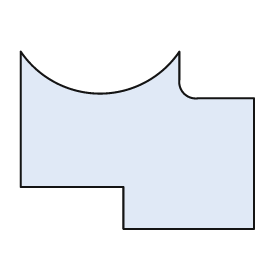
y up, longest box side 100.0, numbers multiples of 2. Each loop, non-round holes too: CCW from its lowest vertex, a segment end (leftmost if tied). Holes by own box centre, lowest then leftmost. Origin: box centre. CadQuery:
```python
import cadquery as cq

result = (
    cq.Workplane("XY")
    .moveTo(-6.0, -38.0)
    .lineTo(50.0, -38.0)
    .lineTo(50.0, 18.0)
    .lineTo(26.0, 18.0)
    .threePointArc((20.0, 20.0), (18.0, 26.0))
    .lineTo(18.0, 38.0)
    .threePointArc((-16.0, 20.0), (-50.0, 38.0))
    .lineTo(-50.0, -20.0)
    .lineTo(-6.0, -20.0)
    .close()
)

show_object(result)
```